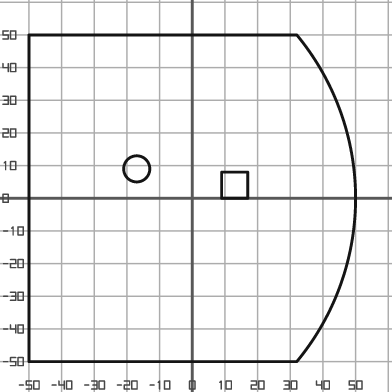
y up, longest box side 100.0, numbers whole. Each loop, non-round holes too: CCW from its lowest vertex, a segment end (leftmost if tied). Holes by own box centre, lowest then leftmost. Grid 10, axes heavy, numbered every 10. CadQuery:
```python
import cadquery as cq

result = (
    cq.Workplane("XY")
    .moveTo(-50.0, -50.0)
    .lineTo(32.0, -50.0)
    .threePointArc((50.0, 0.0), (32.0, 50.0))
    .lineTo(-50.0, 50.0)
    .close()
    .moveTo(9.0, 0.0)
    .lineTo(17.0, 0.0)
    .lineTo(17.0, 8.0)
    .lineTo(9.0, 8.0)
    .close()
    .moveTo(-17.0, 9.0)
    .circle(4.0)
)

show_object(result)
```